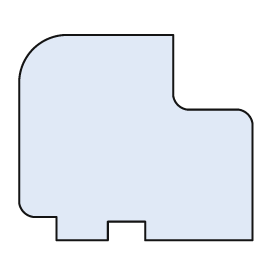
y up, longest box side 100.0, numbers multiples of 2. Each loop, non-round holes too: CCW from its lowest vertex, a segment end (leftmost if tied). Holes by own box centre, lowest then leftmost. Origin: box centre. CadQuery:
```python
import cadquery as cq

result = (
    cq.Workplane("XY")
    .moveTo(-34.0, -44.0)
    .lineTo(-12.0, -44.0)
    .lineTo(-12.0, -36.0)
    .lineTo(4.0, -36.0)
    .lineTo(4.0, -44.0)
    .lineTo(50.0, -44.0)
    .lineTo(50.0, 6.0)
    .threePointArc((48.0, 10.0), (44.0, 12.0))
    .lineTo(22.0, 12.0)
    .threePointArc((18.0, 14.0), (16.0, 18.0))
    .lineTo(16.0, 44.0)
    .lineTo(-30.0, 44.0)
    .threePointArc((-44.0, 38.0), (-50.0, 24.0))
    .lineTo(-50.0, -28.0)
    .threePointArc((-48.0, -32.0), (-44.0, -34.0))
    .lineTo(-34.0, -34.0)
    .close()
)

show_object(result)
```